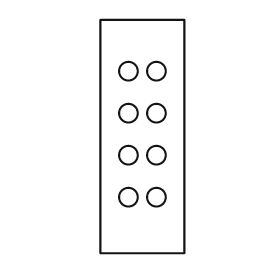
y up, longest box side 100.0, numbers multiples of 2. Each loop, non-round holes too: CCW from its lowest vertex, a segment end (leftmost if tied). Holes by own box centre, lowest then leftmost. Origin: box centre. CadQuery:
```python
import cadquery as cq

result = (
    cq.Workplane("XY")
    .moveTo(-18.0, -50.0)
    .lineTo(18.0, -50.0)
    .lineTo(18.0, 50.0)
    .lineTo(-18.0, 50.0)
    .close()
    .moveTo(-6.0, -26.0)
    .circle(4.0)
    .moveTo(6.0, -26.0)
    .circle(4.0)
    .moveTo(-6.0, -8.0)
    .circle(4.0)
    .moveTo(6.0, -8.0)
    .circle(4.0)
    .moveTo(-6.0, 10.0)
    .circle(4.0)
    .moveTo(6.0, 10.0)
    .circle(4.0)
    .moveTo(-6.0, 28.0)
    .circle(4.0)
    .moveTo(6.0, 28.0)
    .circle(4.0)
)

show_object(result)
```